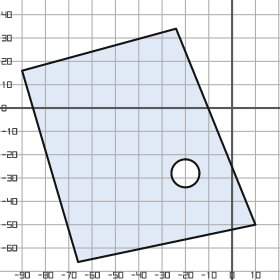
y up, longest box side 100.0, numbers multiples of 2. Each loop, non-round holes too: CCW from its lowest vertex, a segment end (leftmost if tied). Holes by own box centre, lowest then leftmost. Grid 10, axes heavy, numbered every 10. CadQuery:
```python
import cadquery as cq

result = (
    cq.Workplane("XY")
    .moveTo(-66.0, -66.0)
    .lineTo(10.0, -50.0)
    .lineTo(-24.0, 34.0)
    .lineTo(-90.0, 16.0)
    .close()
    .moveTo(-20.0, -28.0)
    .circle(6.0)
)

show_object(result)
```